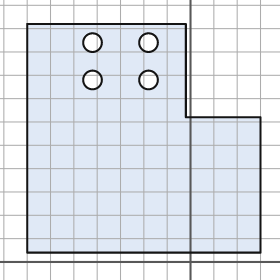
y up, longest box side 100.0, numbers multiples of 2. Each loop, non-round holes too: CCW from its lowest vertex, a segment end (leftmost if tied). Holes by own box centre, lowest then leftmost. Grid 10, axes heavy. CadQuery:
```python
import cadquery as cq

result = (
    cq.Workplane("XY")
    .moveTo(-70.0, 4.0)
    .lineTo(30.0, 4.0)
    .lineTo(30.0, 62.0)
    .lineTo(-2.0, 62.0)
    .lineTo(-2.0, 102.0)
    .lineTo(-70.0, 102.0)
    .close()
    .moveTo(-42.0, 78.0)
    .circle(4.0)
    .moveTo(-18.0, 78.0)
    .circle(4.0)
    .moveTo(-42.0, 94.0)
    .circle(4.0)
    .moveTo(-18.0, 94.0)
    .circle(4.0)
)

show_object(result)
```